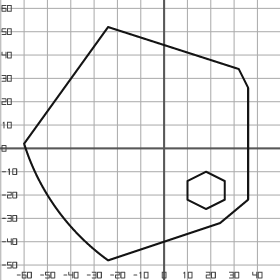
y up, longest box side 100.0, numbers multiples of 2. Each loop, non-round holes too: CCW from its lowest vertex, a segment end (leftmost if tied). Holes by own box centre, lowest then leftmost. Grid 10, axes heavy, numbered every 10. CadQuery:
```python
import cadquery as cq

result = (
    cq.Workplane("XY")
    .moveTo(-24.0, -48.0)
    .lineTo(24.0, -32.0)
    .lineTo(36.0, -22.0)
    .lineTo(36.0, 26.0)
    .lineTo(32.0, 34.0)
    .lineTo(-24.0, 52.0)
    .lineTo(-60.0, 2.0)
    .threePointArc((-46.0, -26.0), (-24.0, -48.0))
    .close()
    .moveTo(18.0, -26.0)
    .lineTo(26.0, -22.0)
    .lineTo(26.0, -14.0)
    .lineTo(18.0, -10.0)
    .lineTo(10.0, -14.0)
    .lineTo(10.0, -22.0)
    .close()
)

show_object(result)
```